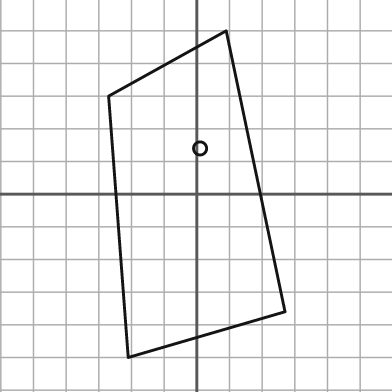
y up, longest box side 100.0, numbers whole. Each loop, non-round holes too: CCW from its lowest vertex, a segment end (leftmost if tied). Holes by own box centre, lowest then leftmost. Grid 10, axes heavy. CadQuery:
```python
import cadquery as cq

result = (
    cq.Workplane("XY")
    .moveTo(-21.0, -50.0)
    .lineTo(27.0, -36.0)
    .lineTo(9.0, 50.0)
    .lineTo(-27.0, 30.0)
    .close()
    .moveTo(1.0, 14.0)
    .circle(2.0)
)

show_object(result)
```